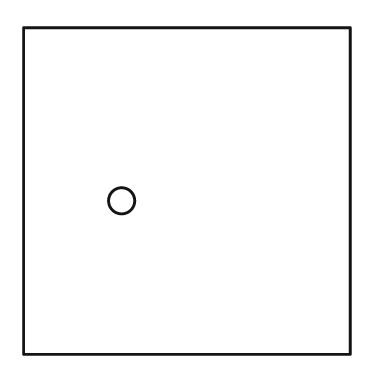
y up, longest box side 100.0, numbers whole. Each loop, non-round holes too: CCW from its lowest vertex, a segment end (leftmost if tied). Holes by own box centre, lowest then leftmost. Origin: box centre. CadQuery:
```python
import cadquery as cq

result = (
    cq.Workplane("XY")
    .moveTo(-50.0, -50.0)
    .lineTo(50.0, -50.0)
    .lineTo(50.0, 50.0)
    .lineTo(-50.0, 50.0)
    .close()
    .moveTo(-20.0, -3.0)
    .circle(4.0)
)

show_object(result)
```